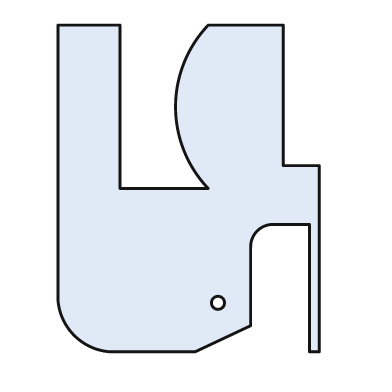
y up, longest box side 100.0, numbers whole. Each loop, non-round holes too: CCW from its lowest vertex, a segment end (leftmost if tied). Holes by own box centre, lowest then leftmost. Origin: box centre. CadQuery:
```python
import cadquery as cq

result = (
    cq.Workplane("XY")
    .moveTo(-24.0, -50.0)
    .lineTo(2.0, -50.0)
    .lineTo(19.0, -42.0)
    .lineTo(19.0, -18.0)
    .threePointArc((21.0, -13.0), (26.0, -11.0))
    .lineTo(37.0, -11.0)
    .lineTo(37.0, -50.0)
    .lineTo(40.0, -50.0)
    .lineTo(40.0, 7.0)
    .lineTo(29.0, 7.0)
    .lineTo(29.0, 50.0)
    .lineTo(6.0, 50.0)
    .threePointArc((-4.0, 25.0), (6.0, 0.0))
    .lineTo(-21.0, 0.0)
    .lineTo(-21.0, 50.0)
    .lineTo(-40.0, 50.0)
    .lineTo(-40.0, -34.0)
    .threePointArc((-35.0, -45.0), (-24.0, -50.0))
    .close()
    .moveTo(9.0, -35.0)
    .circle(2.0)
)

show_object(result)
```